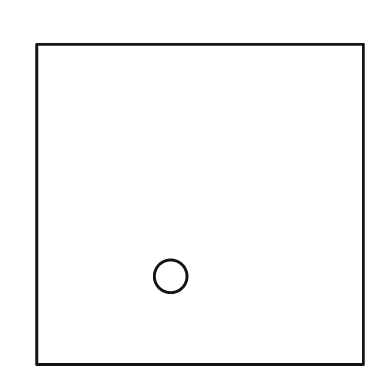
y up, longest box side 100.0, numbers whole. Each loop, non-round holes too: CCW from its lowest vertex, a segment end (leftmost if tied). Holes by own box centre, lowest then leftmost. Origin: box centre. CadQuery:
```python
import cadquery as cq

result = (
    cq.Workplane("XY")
    .moveTo(-50.0, -49.0)
    .lineTo(50.0, -49.0)
    .lineTo(50.0, 49.0)
    .lineTo(-50.0, 49.0)
    .close()
    .moveTo(-9.0, -22.0)
    .circle(5.0)
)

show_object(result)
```